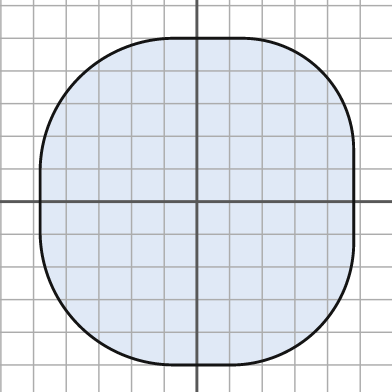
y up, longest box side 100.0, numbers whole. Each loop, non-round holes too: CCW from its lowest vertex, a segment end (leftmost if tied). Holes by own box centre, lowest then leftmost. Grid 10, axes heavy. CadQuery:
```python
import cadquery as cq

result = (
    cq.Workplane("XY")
    .moveTo(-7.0, -50.0)
    .lineTo(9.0, -50.0)
    .threePointArc((37.0, -39.0), (48.0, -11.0))
    .lineTo(48.0, 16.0)
    .threePointArc((38.0, 40.0), (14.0, 50.0))
    .lineTo(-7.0, 50.0)
    .threePointArc((-36.0, 38.0), (-48.0, 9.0))
    .lineTo(-48.0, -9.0)
    .threePointArc((-36.0, -38.0), (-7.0, -50.0))
    .close()
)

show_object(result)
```